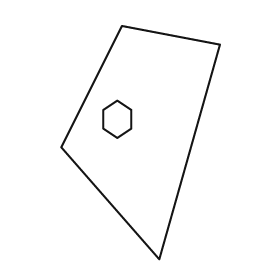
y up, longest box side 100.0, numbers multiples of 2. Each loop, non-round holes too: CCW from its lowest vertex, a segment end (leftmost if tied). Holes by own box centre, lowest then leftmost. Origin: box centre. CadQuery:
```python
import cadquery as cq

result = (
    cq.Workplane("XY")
    .moveTo(8.0, -50.0)
    .lineTo(34.0, 42.0)
    .lineTo(-8.0, 50.0)
    .lineTo(-34.0, -2.0)
    .close()
    .moveTo(-10.0, 2.0)
    .lineTo(-4.0, 6.0)
    .lineTo(-4.0, 14.0)
    .lineTo(-10.0, 18.0)
    .lineTo(-16.0, 14.0)
    .lineTo(-16.0, 6.0)
    .close()
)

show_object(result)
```